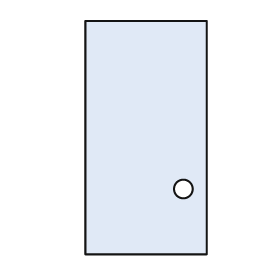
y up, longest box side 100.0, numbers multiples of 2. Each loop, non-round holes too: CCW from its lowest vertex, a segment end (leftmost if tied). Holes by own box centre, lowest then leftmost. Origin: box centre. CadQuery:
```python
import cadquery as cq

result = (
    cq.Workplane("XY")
    .moveTo(-26.0, -50.0)
    .lineTo(26.0, -50.0)
    .lineTo(26.0, 50.0)
    .lineTo(-26.0, 50.0)
    .close()
    .moveTo(16.0, -22.0)
    .circle(4.0)
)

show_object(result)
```